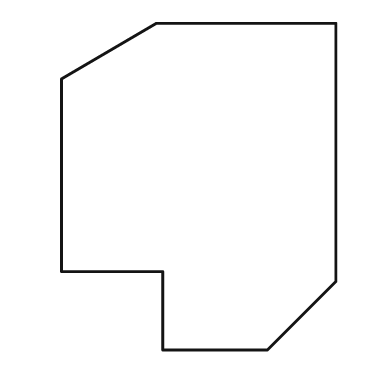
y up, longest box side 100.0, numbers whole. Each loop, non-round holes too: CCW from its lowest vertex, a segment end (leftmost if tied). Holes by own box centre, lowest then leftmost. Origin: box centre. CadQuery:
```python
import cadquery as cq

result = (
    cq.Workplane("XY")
    .moveTo(-11.0, -50.0)
    .lineTo(21.0, -50.0)
    .lineTo(42.0, -29.0)
    .lineTo(42.0, 50.0)
    .lineTo(-13.0, 50.0)
    .lineTo(-42.0, 33.0)
    .lineTo(-42.0, -26.0)
    .lineTo(-11.0, -26.0)
    .close()
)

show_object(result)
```